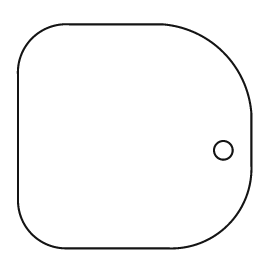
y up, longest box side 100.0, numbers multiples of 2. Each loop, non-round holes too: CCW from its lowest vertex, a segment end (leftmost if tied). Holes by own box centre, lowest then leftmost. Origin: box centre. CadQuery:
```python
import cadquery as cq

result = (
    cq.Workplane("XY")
    .moveTo(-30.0, -48.0)
    .lineTo(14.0, -48.0)
    .threePointArc((40.0, -38.0), (50.0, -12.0))
    .lineTo(50.0, 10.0)
    .threePointArc((38.0, 36.0), (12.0, 48.0))
    .lineTo(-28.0, 48.0)
    .threePointArc((-44.0, 42.0), (-50.0, 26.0))
    .lineTo(-50.0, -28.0)
    .threePointArc((-44.0, -42.0), (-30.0, -48.0))
    .close()
    .moveTo(38.0, -6.0)
    .circle(4.0)
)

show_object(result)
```